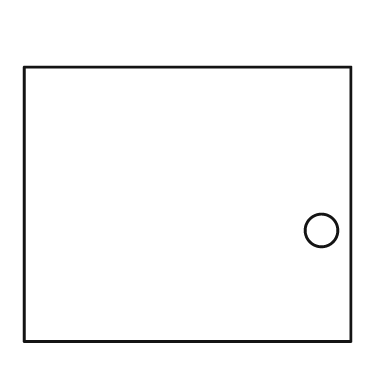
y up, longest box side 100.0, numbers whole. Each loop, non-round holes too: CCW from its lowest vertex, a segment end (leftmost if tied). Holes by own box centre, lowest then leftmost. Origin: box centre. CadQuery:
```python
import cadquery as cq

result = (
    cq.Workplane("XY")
    .moveTo(-50.0, -42.0)
    .lineTo(50.0, -42.0)
    .lineTo(50.0, 42.0)
    .lineTo(-50.0, 42.0)
    .close()
    .moveTo(41.0, -8.0)
    .circle(5.0)
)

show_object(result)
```